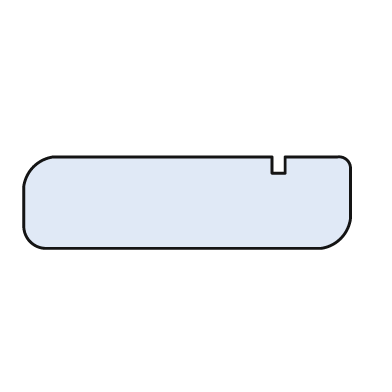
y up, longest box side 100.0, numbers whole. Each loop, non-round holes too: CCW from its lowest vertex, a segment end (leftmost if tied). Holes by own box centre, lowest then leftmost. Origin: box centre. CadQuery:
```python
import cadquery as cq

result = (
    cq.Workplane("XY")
    .moveTo(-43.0, -14.0)
    .lineTo(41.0, -14.0)
    .threePointArc((47.0, -11.0), (50.0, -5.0))
    .lineTo(50.0, 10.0)
    .threePointArc((49.0, 13.0), (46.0, 14.0))
    .lineTo(30.0, 14.0)
    .lineTo(30.0, 9.0)
    .lineTo(26.0, 9.0)
    .lineTo(26.0, 14.0)
    .lineTo(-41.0, 14.0)
    .threePointArc((-47.0, 11.0), (-50.0, 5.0))
    .lineTo(-50.0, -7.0)
    .threePointArc((-48.0, -12.0), (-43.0, -14.0))
    .close()
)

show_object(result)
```